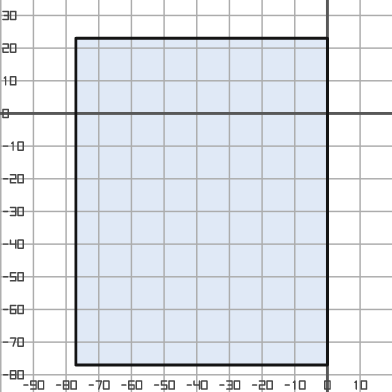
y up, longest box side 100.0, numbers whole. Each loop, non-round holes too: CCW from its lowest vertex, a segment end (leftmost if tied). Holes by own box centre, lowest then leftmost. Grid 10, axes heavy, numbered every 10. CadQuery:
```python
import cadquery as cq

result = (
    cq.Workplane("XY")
    .moveTo(-77.0, -77.0)
    .lineTo(0.0, -77.0)
    .lineTo(0.0, 23.0)
    .lineTo(-77.0, 23.0)
    .close()
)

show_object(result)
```